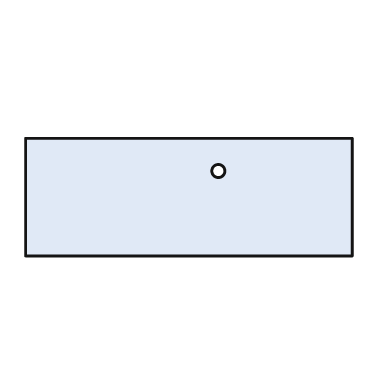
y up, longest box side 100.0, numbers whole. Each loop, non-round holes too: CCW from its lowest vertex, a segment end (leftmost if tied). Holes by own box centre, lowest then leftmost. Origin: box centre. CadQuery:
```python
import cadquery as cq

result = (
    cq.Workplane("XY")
    .moveTo(-50.0, -18.0)
    .lineTo(50.0, -18.0)
    .lineTo(50.0, 18.0)
    .lineTo(-50.0, 18.0)
    .close()
    .moveTo(9.0, 8.0)
    .circle(2.0)
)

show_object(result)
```